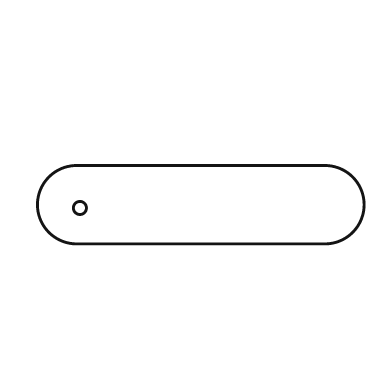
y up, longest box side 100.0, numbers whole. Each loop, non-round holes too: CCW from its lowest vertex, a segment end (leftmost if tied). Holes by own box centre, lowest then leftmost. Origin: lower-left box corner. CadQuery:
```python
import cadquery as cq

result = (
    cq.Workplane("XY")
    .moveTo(12.0, 0.0)
    .lineTo(88.0, 0.0)
    .threePointArc((100.0, 12.0), (88.0, 24.0))
    .lineTo(12.0, 24.0)
    .threePointArc((0.0, 12.0), (12.0, 0.0))
    .close()
    .moveTo(13.0, 11.0)
    .circle(2.0)
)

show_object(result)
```